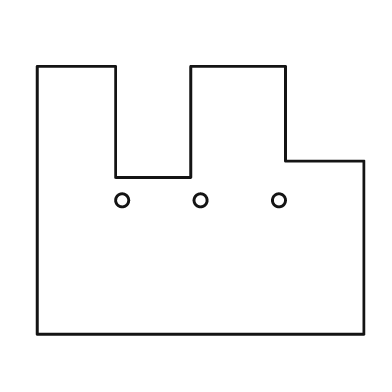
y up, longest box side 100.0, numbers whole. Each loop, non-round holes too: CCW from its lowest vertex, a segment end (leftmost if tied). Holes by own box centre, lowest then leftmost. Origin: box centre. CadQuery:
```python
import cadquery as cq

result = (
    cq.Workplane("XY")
    .moveTo(-50.0, -41.0)
    .lineTo(50.0, -41.0)
    .lineTo(50.0, 12.0)
    .lineTo(26.0, 12.0)
    .lineTo(26.0, 41.0)
    .lineTo(-3.0, 41.0)
    .lineTo(-3.0, 7.0)
    .lineTo(-26.0, 7.0)
    .lineTo(-26.0, 41.0)
    .lineTo(-50.0, 41.0)
    .close()
    .moveTo(-24.0, 0.0)
    .circle(2.0)
    .moveTo(0.0, 0.0)
    .circle(2.0)
    .moveTo(24.0, 0.0)
    .circle(2.0)
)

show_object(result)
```